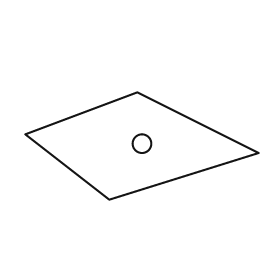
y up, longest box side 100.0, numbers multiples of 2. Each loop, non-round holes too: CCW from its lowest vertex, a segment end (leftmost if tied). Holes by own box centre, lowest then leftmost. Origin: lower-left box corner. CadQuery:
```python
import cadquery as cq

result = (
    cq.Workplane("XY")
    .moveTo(36.0, 0.0)
    .lineTo(100.0, 20.0)
    .lineTo(48.0, 46.0)
    .lineTo(0.0, 28.0)
    .close()
    .moveTo(50.0, 24.0)
    .circle(4.0)
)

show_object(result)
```